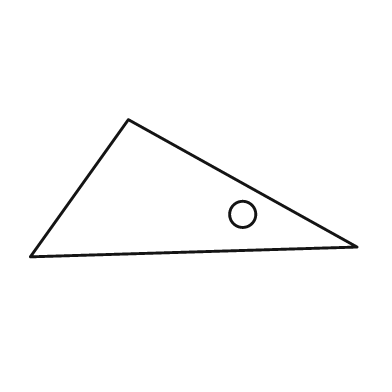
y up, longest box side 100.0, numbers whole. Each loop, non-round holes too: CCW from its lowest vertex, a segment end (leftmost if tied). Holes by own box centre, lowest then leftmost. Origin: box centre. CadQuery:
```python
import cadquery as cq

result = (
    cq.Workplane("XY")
    .moveTo(-50.0, -21.0)
    .lineTo(50.0, -18.0)
    .lineTo(-20.0, 21.0)
    .close()
    .moveTo(15.0, -8.0)
    .circle(4.0)
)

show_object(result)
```